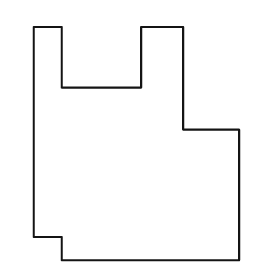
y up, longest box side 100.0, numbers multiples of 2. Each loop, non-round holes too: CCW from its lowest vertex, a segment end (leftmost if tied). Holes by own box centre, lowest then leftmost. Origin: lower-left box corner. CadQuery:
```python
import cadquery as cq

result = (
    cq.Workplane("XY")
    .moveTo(12.0, 0.0)
    .lineTo(88.0, 0.0)
    .lineTo(88.0, 56.0)
    .lineTo(64.0, 56.0)
    .lineTo(64.0, 100.0)
    .lineTo(46.0, 100.0)
    .lineTo(46.0, 74.0)
    .lineTo(12.0, 74.0)
    .lineTo(12.0, 100.0)
    .lineTo(0.0, 100.0)
    .lineTo(0.0, 10.0)
    .lineTo(12.0, 10.0)
    .close()
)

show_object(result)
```